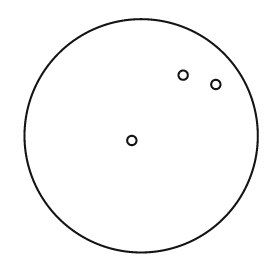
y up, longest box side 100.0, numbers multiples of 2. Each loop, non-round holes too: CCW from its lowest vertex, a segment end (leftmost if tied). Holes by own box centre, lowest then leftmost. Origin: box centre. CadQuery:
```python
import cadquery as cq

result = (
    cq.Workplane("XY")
    .moveTo(0.0, 0.0)
    .circle(50.0)
    .moveTo(-4.0, -2.0)
    .circle(2.0)
    .moveTo(32.0, 22.0)
    .circle(2.0)
    .moveTo(18.0, 26.0)
    .circle(2.0)
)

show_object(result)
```